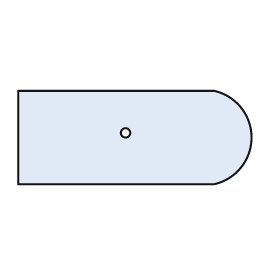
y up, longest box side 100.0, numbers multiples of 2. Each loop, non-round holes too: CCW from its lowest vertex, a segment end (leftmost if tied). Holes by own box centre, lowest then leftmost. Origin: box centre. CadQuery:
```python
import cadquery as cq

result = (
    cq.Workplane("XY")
    .moveTo(-50.0, -20.0)
    .lineTo(34.0, -20.0)
    .threePointArc((50.0, 0.0), (34.0, 20.0))
    .lineTo(-50.0, 20.0)
    .close()
    .moveTo(-4.0, 2.0)
    .circle(2.0)
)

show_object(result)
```